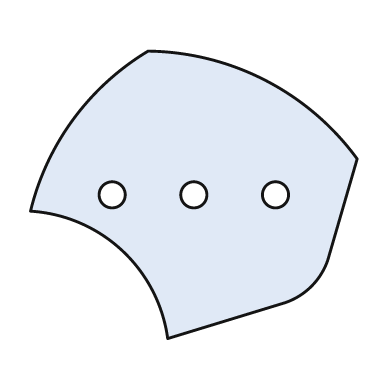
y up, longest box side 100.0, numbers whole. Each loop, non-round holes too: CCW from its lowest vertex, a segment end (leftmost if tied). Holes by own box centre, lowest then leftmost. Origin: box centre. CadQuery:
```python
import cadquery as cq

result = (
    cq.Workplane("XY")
    .moveTo(-8.0, -44.0)
    .lineTo(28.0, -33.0)
    .threePointArc((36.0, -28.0), (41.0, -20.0))
    .lineTo(50.0, 11.0)
    .threePointArc((22.0, 35.0), (-14.0, 44.0))
    .threePointArc((-37.0, 23.0), (-50.0, -5.0))
    .threePointArc((-22.0, -17.0), (-8.0, -44.0))
    .close()
    .moveTo(-25.0, 0.0)
    .circle(4.0)
    .moveTo(0.0, 0.0)
    .circle(4.0)
    .moveTo(25.0, 0.0)
    .circle(4.0)
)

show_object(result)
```